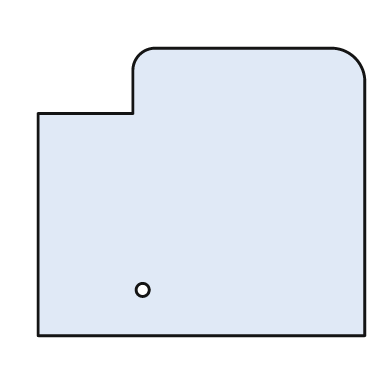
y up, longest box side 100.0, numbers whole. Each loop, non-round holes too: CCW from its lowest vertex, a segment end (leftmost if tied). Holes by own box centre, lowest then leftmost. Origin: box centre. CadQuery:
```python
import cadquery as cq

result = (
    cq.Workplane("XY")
    .moveTo(-50.0, -44.0)
    .lineTo(50.0, -44.0)
    .lineTo(50.0, 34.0)
    .threePointArc((47.0, 41.0), (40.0, 44.0))
    .lineTo(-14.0, 44.0)
    .threePointArc((-19.0, 42.0), (-21.0, 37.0))
    .lineTo(-21.0, 24.0)
    .lineTo(-50.0, 24.0)
    .close()
    .moveTo(-18.0, -30.0)
    .circle(2.0)
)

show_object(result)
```